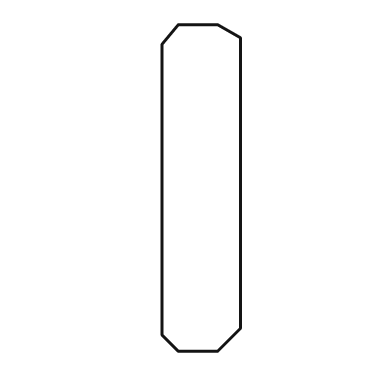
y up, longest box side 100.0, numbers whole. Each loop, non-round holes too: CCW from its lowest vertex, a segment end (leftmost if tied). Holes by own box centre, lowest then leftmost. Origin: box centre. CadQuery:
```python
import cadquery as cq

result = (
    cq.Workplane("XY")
    .moveTo(-7.0, -50.0)
    .lineTo(5.0, -50.0)
    .lineTo(12.0, -43.0)
    .lineTo(12.0, 46.0)
    .lineTo(5.0, 50.0)
    .lineTo(-7.0, 50.0)
    .lineTo(-12.0, 44.0)
    .lineTo(-12.0, -45.0)
    .close()
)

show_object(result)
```